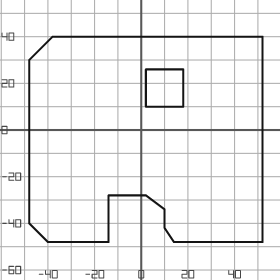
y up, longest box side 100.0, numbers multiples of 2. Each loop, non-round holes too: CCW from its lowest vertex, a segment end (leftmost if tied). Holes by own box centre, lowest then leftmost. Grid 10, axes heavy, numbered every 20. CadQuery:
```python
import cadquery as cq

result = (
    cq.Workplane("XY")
    .moveTo(-40.0, -48.0)
    .lineTo(-14.0, -48.0)
    .lineTo(-14.0, -28.0)
    .lineTo(2.0, -28.0)
    .lineTo(10.0, -34.0)
    .lineTo(10.0, -42.0)
    .lineTo(14.0, -48.0)
    .lineTo(52.0, -48.0)
    .lineTo(52.0, 40.0)
    .lineTo(-38.0, 40.0)
    .lineTo(-48.0, 30.0)
    .lineTo(-48.0, -40.0)
    .close()
    .moveTo(2.0, 10.0)
    .lineTo(18.0, 10.0)
    .lineTo(18.0, 26.0)
    .lineTo(2.0, 26.0)
    .close()
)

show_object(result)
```